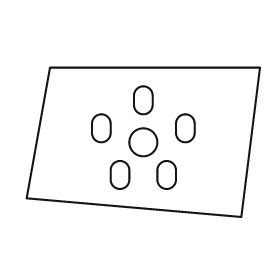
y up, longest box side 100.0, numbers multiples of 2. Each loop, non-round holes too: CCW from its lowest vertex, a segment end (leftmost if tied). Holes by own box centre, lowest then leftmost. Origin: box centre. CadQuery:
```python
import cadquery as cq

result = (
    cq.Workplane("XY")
    .moveTo(42.0, -32.0)
    .lineTo(50.0, 32.0)
    .lineTo(-40.0, 32.0)
    .lineTo(-50.0, -24.0)
    .close()
    .moveTo(-14.0, -16.0)
    .threePointArc((-10.0, -20.0), (-6.0, -16.0))
    .lineTo(-6.0, -12.0)
    .threePointArc((-10.0, -8.0), (-14.0, -12.0))
    .close()
    .moveTo(6.0, -16.0)
    .threePointArc((10.0, -20.0), (14.0, -16.0))
    .lineTo(14.0, -12.0)
    .threePointArc((10.0, -8.0), (6.0, -12.0))
    .close()
    .moveTo(0.0, 0.0)
    .circle(6.0)
    .moveTo(-22.0, 4.0)
    .threePointArc((-18.0, 0.0), (-14.0, 4.0))
    .lineTo(-14.0, 8.0)
    .threePointArc((-18.0, 12.0), (-22.0, 8.0))
    .close()
    .moveTo(14.0, 4.0)
    .threePointArc((18.0, 0.0), (22.0, 4.0))
    .lineTo(22.0, 8.0)
    .threePointArc((18.0, 12.0), (14.0, 8.0))
    .close()
    .moveTo(-4.0, 16.0)
    .threePointArc((0.0, 12.0), (4.0, 16.0))
    .lineTo(4.0, 20.0)
    .threePointArc((0.0, 24.0), (-4.0, 20.0))
    .close()
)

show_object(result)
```